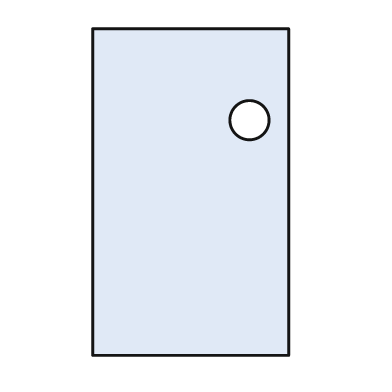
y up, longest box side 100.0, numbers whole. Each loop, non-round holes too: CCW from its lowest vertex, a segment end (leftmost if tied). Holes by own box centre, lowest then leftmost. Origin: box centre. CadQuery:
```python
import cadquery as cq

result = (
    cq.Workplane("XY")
    .moveTo(-30.0, -50.0)
    .lineTo(30.0, -50.0)
    .lineTo(30.0, 50.0)
    .lineTo(-30.0, 50.0)
    .close()
    .moveTo(18.0, 22.0)
    .circle(6.0)
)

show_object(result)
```